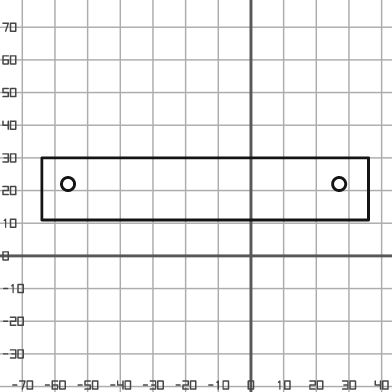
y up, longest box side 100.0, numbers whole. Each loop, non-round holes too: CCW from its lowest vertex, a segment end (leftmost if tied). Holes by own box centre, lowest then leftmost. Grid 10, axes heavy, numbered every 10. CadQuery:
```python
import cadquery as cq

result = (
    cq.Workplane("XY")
    .moveTo(-64.0, 11.0)
    .lineTo(36.0, 11.0)
    .lineTo(36.0, 30.0)
    .lineTo(-64.0, 30.0)
    .close()
    .moveTo(-56.0, 22.0)
    .circle(2.0)
    .moveTo(27.0, 22.0)
    .circle(2.0)
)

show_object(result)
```